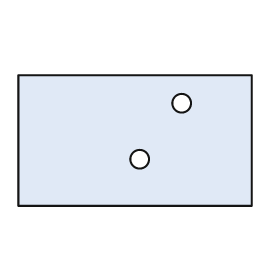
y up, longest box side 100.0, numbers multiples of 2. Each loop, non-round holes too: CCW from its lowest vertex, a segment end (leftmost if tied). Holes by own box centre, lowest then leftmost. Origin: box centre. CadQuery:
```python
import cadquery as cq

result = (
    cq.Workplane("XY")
    .moveTo(-50.0, -28.0)
    .lineTo(50.0, -28.0)
    .lineTo(50.0, 28.0)
    .lineTo(-50.0, 28.0)
    .close()
    .moveTo(2.0, -8.0)
    .circle(4.0)
    .moveTo(20.0, 16.0)
    .circle(4.0)
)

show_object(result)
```